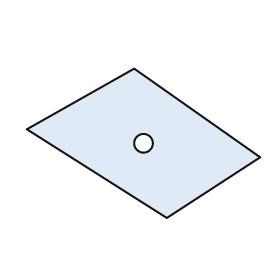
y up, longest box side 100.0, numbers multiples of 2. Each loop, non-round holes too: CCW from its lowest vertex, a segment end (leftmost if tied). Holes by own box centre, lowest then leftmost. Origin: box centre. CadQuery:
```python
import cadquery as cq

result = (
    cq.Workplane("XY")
    .moveTo(10.0, -32.0)
    .lineTo(50.0, -6.0)
    .lineTo(-4.0, 32.0)
    .lineTo(-50.0, 6.0)
    .close()
    .moveTo(0.0, 0.0)
    .circle(4.0)
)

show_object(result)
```